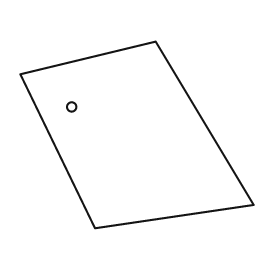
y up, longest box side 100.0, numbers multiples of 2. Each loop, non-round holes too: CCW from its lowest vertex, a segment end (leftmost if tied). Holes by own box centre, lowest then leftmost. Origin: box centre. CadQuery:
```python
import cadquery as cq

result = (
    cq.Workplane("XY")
    .moveTo(-18.0, -40.0)
    .lineTo(50.0, -30.0)
    .lineTo(8.0, 40.0)
    .lineTo(-50.0, 26.0)
    .close()
    .moveTo(-28.0, 12.0)
    .circle(2.0)
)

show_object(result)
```